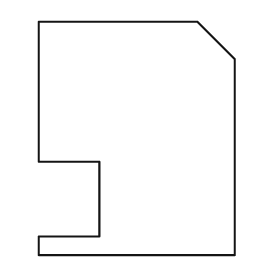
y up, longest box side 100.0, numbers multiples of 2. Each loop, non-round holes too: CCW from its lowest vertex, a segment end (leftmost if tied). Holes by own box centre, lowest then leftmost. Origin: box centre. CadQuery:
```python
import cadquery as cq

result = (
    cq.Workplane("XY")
    .moveTo(-42.0, -50.0)
    .lineTo(42.0, -50.0)
    .lineTo(42.0, 34.0)
    .lineTo(26.0, 50.0)
    .lineTo(-42.0, 50.0)
    .lineTo(-42.0, -10.0)
    .lineTo(-16.0, -10.0)
    .lineTo(-16.0, -42.0)
    .lineTo(-42.0, -42.0)
    .close()
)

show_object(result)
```